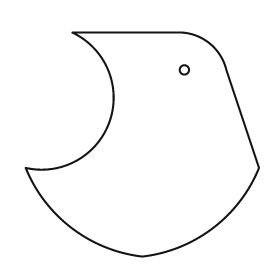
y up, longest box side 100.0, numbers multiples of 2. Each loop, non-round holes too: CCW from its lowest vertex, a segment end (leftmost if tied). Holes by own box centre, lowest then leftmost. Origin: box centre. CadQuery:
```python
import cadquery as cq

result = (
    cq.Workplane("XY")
    .moveTo(0.0, -48.0)
    .threePointArc((30.0, -36.0), (50.0, -10.0))
    .lineTo(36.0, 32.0)
    .threePointArc((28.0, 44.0), (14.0, 48.0))
    .lineTo(-30.0, 48.0)
    .threePointArc((-14.0, 10.0), (-50.0, -10.0))
    .threePointArc((-30.0, -36.0), (0.0, -48.0))
    .close()
    .moveTo(18.0, 32.0)
    .circle(2.0)
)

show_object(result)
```